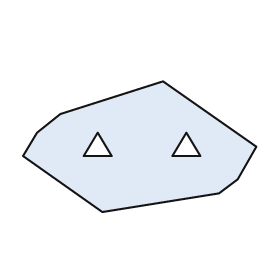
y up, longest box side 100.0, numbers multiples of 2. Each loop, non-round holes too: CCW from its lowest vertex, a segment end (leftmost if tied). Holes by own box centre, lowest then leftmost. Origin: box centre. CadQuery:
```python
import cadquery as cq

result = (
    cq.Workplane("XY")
    .moveTo(-16.0, -28.0)
    .lineTo(34.0, -20.0)
    .lineTo(42.0, -14.0)
    .lineTo(50.0, 0.0)
    .lineTo(10.0, 28.0)
    .lineTo(-34.0, 14.0)
    .lineTo(-44.0, 6.0)
    .lineTo(-50.0, -4.0)
    .close()
    .moveTo(-24.0, -4.0)
    .lineTo(-12.0, -4.0)
    .lineTo(-18.0, 6.0)
    .close()
    .moveTo(14.0, -4.0)
    .lineTo(26.0, -4.0)
    .lineTo(20.0, 6.0)
    .close()
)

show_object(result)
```